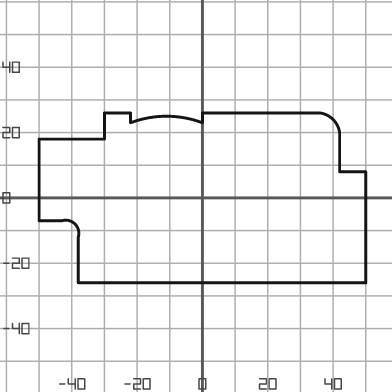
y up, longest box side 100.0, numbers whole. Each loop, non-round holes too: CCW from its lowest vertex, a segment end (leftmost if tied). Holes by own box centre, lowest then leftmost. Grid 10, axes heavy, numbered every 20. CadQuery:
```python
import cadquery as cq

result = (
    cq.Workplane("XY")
    .moveTo(-38.0, -26.0)
    .lineTo(50.0, -26.0)
    .lineTo(50.0, 8.0)
    .lineTo(42.0, 8.0)
    .lineTo(42.0, 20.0)
    .threePointArc((40.0, 24.0), (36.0, 26.0))
    .lineTo(0.0, 26.0)
    .lineTo(0.0, 23.0)
    .threePointArc((-11.0, 25.0), (-22.0, 23.0))
    .lineTo(-22.0, 26.0)
    .lineTo(-30.0, 26.0)
    .lineTo(-30.0, 18.0)
    .lineTo(-50.0, 18.0)
    .lineTo(-50.0, -7.0)
    .lineTo(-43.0, -7.0)
    .threePointArc((-39.0, -8.0), (-38.0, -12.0))
    .close()
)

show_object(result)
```